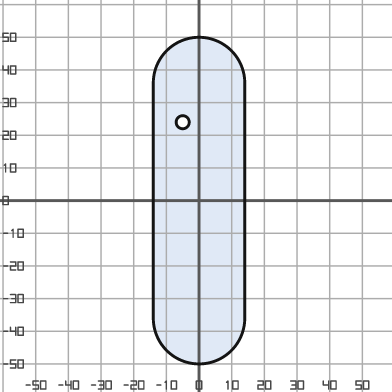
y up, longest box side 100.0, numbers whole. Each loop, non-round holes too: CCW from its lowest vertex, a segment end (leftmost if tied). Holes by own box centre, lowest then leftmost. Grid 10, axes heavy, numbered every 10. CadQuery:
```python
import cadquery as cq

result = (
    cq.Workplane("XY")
    .moveTo(-14.0, -36.0)
    .threePointArc((0.0, -50.0), (14.0, -36.0))
    .lineTo(14.0, 36.0)
    .threePointArc((0.0, 50.0), (-14.0, 36.0))
    .close()
    .moveTo(-5.0, 24.0)
    .circle(2.0)
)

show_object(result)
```